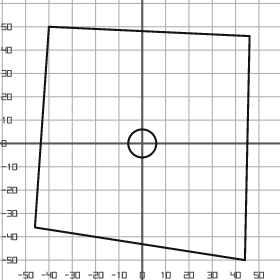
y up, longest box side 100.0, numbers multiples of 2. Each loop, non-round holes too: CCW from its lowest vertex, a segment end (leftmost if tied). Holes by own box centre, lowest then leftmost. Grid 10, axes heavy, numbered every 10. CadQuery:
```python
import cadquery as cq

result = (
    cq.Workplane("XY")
    .moveTo(44.0, -50.0)
    .lineTo(46.0, 46.0)
    .lineTo(-40.0, 50.0)
    .lineTo(-46.0, -36.0)
    .close()
    .moveTo(0.0, 0.0)
    .circle(6.0)
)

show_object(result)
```